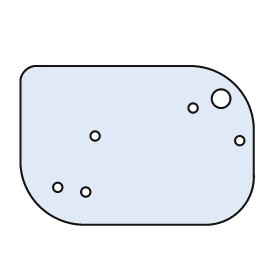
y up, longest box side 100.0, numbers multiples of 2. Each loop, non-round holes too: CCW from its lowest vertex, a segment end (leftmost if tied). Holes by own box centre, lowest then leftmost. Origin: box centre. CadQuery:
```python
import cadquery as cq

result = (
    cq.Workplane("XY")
    .moveTo(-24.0, -34.0)
    .lineTo(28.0, -34.0)
    .threePointArc((44.0, -28.0), (50.0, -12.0))
    .lineTo(50.0, 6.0)
    .threePointArc((42.0, 26.0), (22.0, 34.0))
    .lineTo(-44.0, 34.0)
    .threePointArc((-48.0, 32.0), (-50.0, 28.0))
    .lineTo(-50.0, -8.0)
    .threePointArc((-42.0, -26.0), (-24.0, -34.0))
    .close()
    .moveTo(-22.0, -20.0)
    .circle(2.0)
    .moveTo(-34.0, -18.0)
    .circle(2.0)
    .moveTo(44.0, 2.0)
    .circle(2.0)
    .moveTo(-18.0, 4.0)
    .circle(2.0)
    .moveTo(24.0, 16.0)
    .circle(2.0)
    .moveTo(36.0, 20.0)
    .circle(4.0)
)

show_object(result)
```